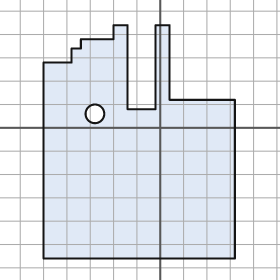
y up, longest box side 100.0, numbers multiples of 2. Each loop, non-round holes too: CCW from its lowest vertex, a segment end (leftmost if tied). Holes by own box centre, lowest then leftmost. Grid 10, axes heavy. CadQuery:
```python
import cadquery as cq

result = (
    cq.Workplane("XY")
    .moveTo(-50.0, -56.0)
    .lineTo(32.0, -56.0)
    .lineTo(32.0, 12.0)
    .lineTo(4.0, 12.0)
    .lineTo(4.0, 44.0)
    .lineTo(-2.0, 44.0)
    .lineTo(-2.0, 8.0)
    .lineTo(-14.0, 8.0)
    .lineTo(-14.0, 44.0)
    .lineTo(-20.0, 44.0)
    .lineTo(-20.0, 38.0)
    .lineTo(-34.0, 38.0)
    .lineTo(-34.0, 34.0)
    .lineTo(-38.0, 34.0)
    .lineTo(-38.0, 28.0)
    .lineTo(-50.0, 28.0)
    .close()
    .moveTo(-28.0, 6.0)
    .circle(4.0)
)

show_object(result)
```